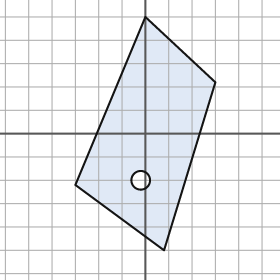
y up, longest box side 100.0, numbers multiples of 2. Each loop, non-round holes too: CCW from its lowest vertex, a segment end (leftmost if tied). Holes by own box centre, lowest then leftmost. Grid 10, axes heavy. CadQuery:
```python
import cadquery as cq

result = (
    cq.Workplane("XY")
    .moveTo(8.0, -50.0)
    .lineTo(30.0, 22.0)
    .lineTo(0.0, 50.0)
    .lineTo(-30.0, -22.0)
    .close()
    .moveTo(-2.0, -20.0)
    .circle(4.0)
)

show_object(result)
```